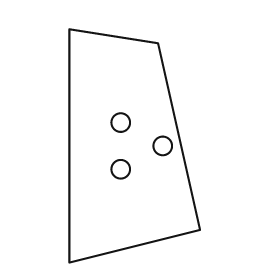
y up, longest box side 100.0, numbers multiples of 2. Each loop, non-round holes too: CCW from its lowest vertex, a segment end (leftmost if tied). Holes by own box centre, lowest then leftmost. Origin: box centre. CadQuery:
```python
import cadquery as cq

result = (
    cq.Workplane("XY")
    .moveTo(-28.0, -50.0)
    .lineTo(28.0, -36.0)
    .lineTo(10.0, 44.0)
    .lineTo(-28.0, 50.0)
    .close()
    .moveTo(-6.0, -10.0)
    .circle(4.0)
    .moveTo(12.0, 0.0)
    .circle(4.0)
    .moveTo(-6.0, 10.0)
    .circle(4.0)
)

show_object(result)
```